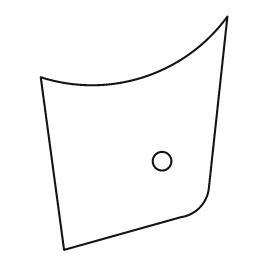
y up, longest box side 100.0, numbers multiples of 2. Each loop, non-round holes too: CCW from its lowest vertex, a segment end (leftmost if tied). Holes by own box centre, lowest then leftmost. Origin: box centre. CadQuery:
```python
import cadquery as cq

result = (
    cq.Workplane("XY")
    .moveTo(-30.0, -50.0)
    .lineTo(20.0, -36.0)
    .threePointArc((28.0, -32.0), (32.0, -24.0))
    .lineTo(40.0, 50.0)
    .threePointArc((4.0, 24.0), (-40.0, 24.0))
    .close()
    .moveTo(12.0, -12.0)
    .circle(4.0)
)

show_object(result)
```